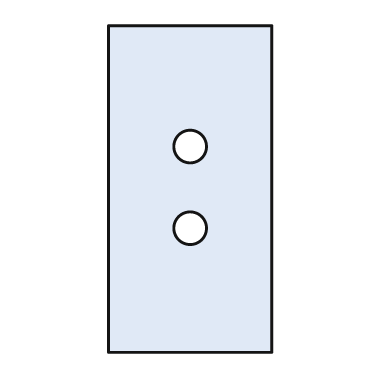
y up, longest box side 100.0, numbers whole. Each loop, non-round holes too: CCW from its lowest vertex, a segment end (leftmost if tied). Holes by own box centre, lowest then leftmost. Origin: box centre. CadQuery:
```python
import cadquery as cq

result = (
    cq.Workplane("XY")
    .moveTo(-25.0, -50.0)
    .lineTo(25.0, -50.0)
    .lineTo(25.0, 50.0)
    .lineTo(-25.0, 50.0)
    .close()
    .moveTo(0.0, -12.0)
    .circle(5.0)
    .moveTo(0.0, 13.0)
    .circle(5.0)
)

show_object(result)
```